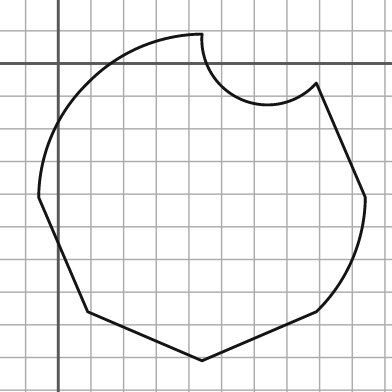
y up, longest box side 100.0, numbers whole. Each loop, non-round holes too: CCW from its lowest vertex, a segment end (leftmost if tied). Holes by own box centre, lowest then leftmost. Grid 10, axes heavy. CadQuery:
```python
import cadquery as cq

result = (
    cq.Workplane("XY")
    .moveTo(44.0, -91.0)
    .lineTo(79.0, -76.0)
    .threePointArc((90.0, -60.0), (94.0, -41.0))
    .lineTo(79.0, -6.0)
    .threePointArc((56.0, -11.0), (44.0, 9.0))
    .threePointArc((25.0, 5.0), (9.0, -6.0))
    .threePointArc((-2.0, -22.0), (-6.0, -41.0))
    .lineTo(9.0, -76.0)
    .close()
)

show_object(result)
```